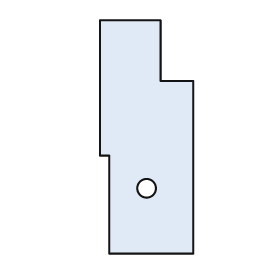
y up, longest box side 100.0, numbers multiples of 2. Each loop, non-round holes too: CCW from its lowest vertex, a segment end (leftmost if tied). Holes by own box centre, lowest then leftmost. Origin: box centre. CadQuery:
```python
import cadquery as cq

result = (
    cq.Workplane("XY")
    .moveTo(-16.0, -50.0)
    .lineTo(20.0, -50.0)
    .lineTo(20.0, 24.0)
    .lineTo(6.0, 24.0)
    .lineTo(6.0, 50.0)
    .lineTo(-20.0, 50.0)
    .lineTo(-20.0, -8.0)
    .lineTo(-16.0, -8.0)
    .close()
    .moveTo(0.0, -22.0)
    .circle(4.0)
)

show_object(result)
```